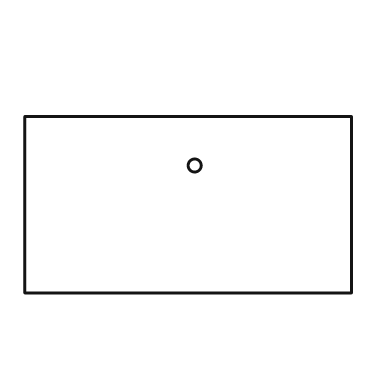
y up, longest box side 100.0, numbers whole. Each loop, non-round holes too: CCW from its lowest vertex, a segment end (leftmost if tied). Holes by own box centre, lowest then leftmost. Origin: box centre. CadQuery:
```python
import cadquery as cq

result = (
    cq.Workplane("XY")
    .moveTo(-50.0, -27.0)
    .lineTo(50.0, -27.0)
    .lineTo(50.0, 27.0)
    .lineTo(-50.0, 27.0)
    .close()
    .moveTo(2.0, 12.0)
    .circle(2.0)
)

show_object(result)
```